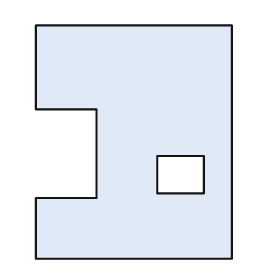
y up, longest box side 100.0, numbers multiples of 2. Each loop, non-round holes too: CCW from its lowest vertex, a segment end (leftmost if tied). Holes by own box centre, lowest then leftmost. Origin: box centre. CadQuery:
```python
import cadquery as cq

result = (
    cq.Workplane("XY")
    .moveTo(-42.0, -50.0)
    .lineTo(42.0, -50.0)
    .lineTo(42.0, 50.0)
    .lineTo(-42.0, 50.0)
    .lineTo(-42.0, 14.0)
    .lineTo(-16.0, 14.0)
    .lineTo(-16.0, -24.0)
    .lineTo(-42.0, -24.0)
    .close()
    .moveTo(10.0, -22.0)
    .lineTo(30.0, -22.0)
    .lineTo(30.0, -6.0)
    .lineTo(10.0, -6.0)
    .close()
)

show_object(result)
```